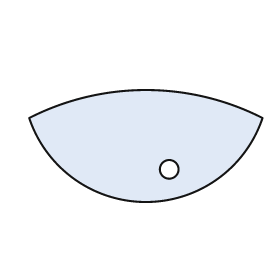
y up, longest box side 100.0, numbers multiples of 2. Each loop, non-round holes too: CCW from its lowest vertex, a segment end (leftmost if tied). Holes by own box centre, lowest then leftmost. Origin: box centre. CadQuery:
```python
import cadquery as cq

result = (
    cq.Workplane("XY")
    .moveTo(-50.0, 12.0)
    .threePointArc((0.0, -24.0), (50.0, 12.0))
    .threePointArc((0.0, 24.0), (-50.0, 12.0))
    .close()
    .moveTo(10.0, -10.0)
    .circle(4.0)
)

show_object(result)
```